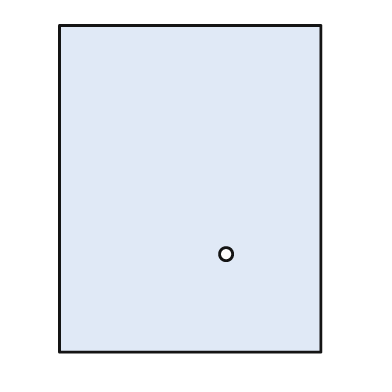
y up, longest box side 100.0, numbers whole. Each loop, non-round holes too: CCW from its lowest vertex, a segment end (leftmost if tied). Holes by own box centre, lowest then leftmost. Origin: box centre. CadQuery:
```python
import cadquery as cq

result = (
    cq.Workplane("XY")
    .moveTo(-40.0, -50.0)
    .lineTo(40.0, -50.0)
    .lineTo(40.0, 50.0)
    .lineTo(-40.0, 50.0)
    .close()
    .moveTo(11.0, -20.0)
    .circle(2.0)
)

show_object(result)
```